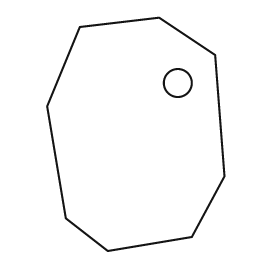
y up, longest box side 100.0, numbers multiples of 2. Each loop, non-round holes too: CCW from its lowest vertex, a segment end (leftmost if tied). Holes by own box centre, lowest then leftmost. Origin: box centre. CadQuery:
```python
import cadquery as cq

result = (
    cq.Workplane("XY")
    .moveTo(-12.0, -50.0)
    .lineTo(24.0, -44.0)
    .lineTo(38.0, -18.0)
    .lineTo(34.0, 34.0)
    .lineTo(10.0, 50.0)
    .lineTo(-24.0, 46.0)
    .lineTo(-38.0, 12.0)
    .lineTo(-30.0, -36.0)
    .close()
    .moveTo(18.0, 22.0)
    .circle(6.0)
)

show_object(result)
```